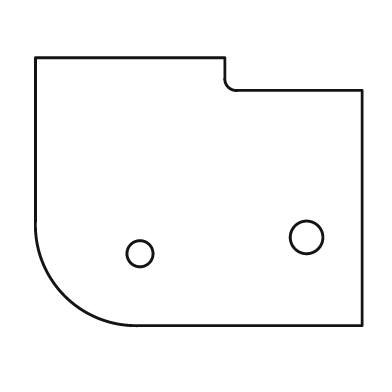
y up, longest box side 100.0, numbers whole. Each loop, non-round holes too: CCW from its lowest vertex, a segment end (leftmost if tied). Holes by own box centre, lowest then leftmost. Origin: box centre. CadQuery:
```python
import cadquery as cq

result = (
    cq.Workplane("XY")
    .moveTo(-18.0, -41.0)
    .lineTo(50.0, -41.0)
    .lineTo(50.0, 31.0)
    .lineTo(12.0, 31.0)
    .threePointArc((9.0, 32.0), (8.0, 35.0))
    .lineTo(8.0, 41.0)
    .lineTo(-50.0, 41.0)
    .lineTo(-50.0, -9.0)
    .threePointArc((-41.0, -32.0), (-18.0, -41.0))
    .close()
    .moveTo(-18.0, -19.0)
    .circle(4.0)
    .moveTo(33.0, -14.0)
    .circle(5.0)
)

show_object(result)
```